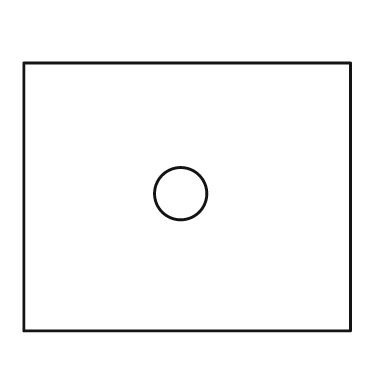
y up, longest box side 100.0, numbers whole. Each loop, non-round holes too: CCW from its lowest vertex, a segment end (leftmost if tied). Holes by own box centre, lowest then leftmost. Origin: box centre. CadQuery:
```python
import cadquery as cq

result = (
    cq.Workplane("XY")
    .moveTo(-50.0, -41.0)
    .lineTo(50.0, -41.0)
    .lineTo(50.0, 41.0)
    .lineTo(-50.0, 41.0)
    .close()
    .moveTo(-2.0, 1.0)
    .circle(8.0)
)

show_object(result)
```